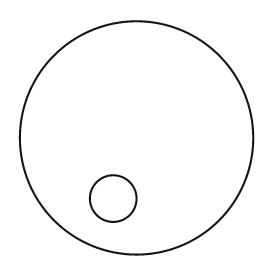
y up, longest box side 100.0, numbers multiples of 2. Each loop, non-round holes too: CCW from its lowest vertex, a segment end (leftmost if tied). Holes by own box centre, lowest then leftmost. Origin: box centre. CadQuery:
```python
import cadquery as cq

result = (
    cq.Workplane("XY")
    .moveTo(0.0, 0.0)
    .circle(50.0)
    .moveTo(-10.0, -26.0)
    .circle(10.0)
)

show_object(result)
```